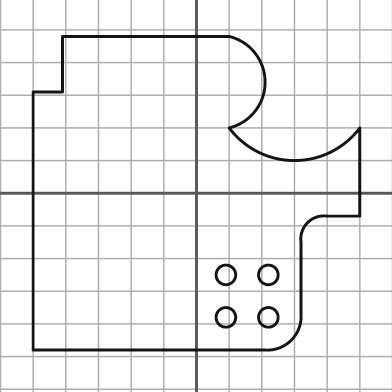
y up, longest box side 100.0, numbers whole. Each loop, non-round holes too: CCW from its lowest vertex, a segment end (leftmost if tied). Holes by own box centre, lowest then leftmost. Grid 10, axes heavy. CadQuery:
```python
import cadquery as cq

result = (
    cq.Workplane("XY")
    .moveTo(-50.0, -48.0)
    .lineTo(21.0, -48.0)
    .threePointArc((29.0, -45.0), (32.0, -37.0))
    .lineTo(32.0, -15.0)
    .threePointArc((34.0, -9.0), (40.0, -7.0))
    .lineTo(50.0, -7.0)
    .lineTo(50.0, 20.0)
    .threePointArc((30.0, 10.0), (10.0, 20.0))
    .threePointArc((21.0, 34.0), (10.0, 48.0))
    .lineTo(-41.0, 48.0)
    .lineTo(-41.0, 31.0)
    .lineTo(-50.0, 31.0)
    .close()
    .moveTo(9.0, -38.0)
    .circle(3.0)
    .moveTo(22.0, -38.0)
    .circle(3.0)
    .moveTo(9.0, -25.0)
    .circle(3.0)
    .moveTo(22.0, -25.0)
    .circle(3.0)
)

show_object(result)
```